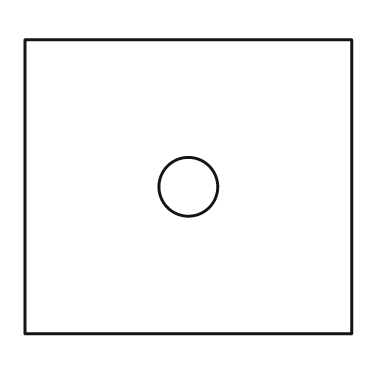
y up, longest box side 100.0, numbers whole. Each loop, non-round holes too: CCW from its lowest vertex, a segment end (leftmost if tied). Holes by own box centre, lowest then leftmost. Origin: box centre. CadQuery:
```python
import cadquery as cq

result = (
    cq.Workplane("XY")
    .moveTo(-50.0, -45.0)
    .lineTo(50.0, -45.0)
    .lineTo(50.0, 45.0)
    .lineTo(-50.0, 45.0)
    .close()
    .moveTo(0.0, 0.0)
    .circle(9.0)
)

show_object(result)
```